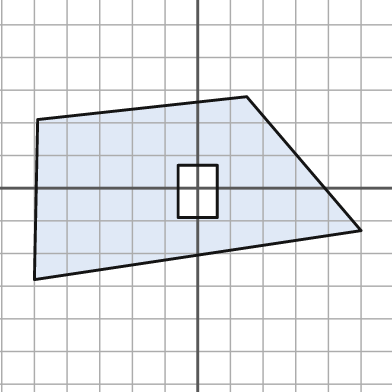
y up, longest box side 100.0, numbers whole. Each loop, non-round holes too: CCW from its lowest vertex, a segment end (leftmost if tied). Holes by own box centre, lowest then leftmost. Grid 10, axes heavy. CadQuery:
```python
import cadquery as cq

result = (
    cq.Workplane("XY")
    .moveTo(-50.0, -28.0)
    .lineTo(50.0, -13.0)
    .lineTo(15.0, 28.0)
    .lineTo(-49.0, 21.0)
    .close()
    .moveTo(-6.0, -9.0)
    .lineTo(6.0, -9.0)
    .lineTo(6.0, 7.0)
    .lineTo(-6.0, 7.0)
    .close()
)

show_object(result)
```